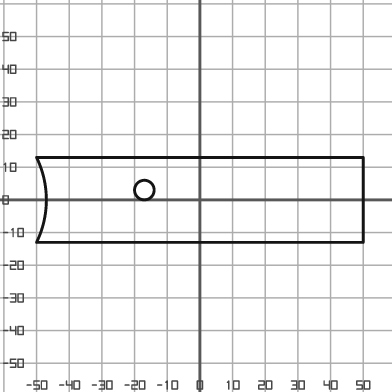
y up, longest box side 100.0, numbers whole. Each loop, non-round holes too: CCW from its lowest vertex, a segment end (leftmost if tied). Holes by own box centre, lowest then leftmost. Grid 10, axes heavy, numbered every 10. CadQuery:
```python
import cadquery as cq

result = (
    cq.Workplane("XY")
    .moveTo(-50.0, -13.0)
    .lineTo(50.0, -13.0)
    .lineTo(50.0, 13.0)
    .lineTo(-50.0, 13.0)
    .threePointArc((-47.0, 0.0), (-50.0, -13.0))
    .close()
    .moveTo(-17.0, 3.0)
    .circle(3.0)
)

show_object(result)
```